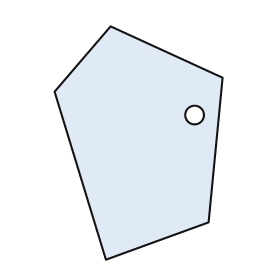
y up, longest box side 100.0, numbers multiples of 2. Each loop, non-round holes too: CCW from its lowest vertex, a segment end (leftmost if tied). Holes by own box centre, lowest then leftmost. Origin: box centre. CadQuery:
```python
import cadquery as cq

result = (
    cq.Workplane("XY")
    .moveTo(-14.0, -50.0)
    .lineTo(30.0, -34.0)
    .lineTo(36.0, 28.0)
    .lineTo(-12.0, 50.0)
    .lineTo(-36.0, 22.0)
    .close()
    .moveTo(24.0, 12.0)
    .circle(4.0)
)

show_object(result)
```